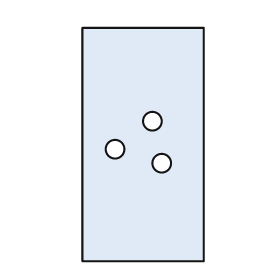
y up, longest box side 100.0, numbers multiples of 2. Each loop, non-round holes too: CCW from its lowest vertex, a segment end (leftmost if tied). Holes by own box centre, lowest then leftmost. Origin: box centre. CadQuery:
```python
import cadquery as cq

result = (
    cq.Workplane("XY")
    .moveTo(-26.0, -50.0)
    .lineTo(26.0, -50.0)
    .lineTo(26.0, 50.0)
    .lineTo(-26.0, 50.0)
    .close()
    .moveTo(8.0, -8.0)
    .circle(4.0)
    .moveTo(-12.0, -2.0)
    .circle(4.0)
    .moveTo(4.0, 10.0)
    .circle(4.0)
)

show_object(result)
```